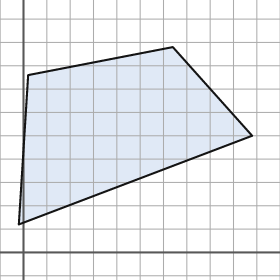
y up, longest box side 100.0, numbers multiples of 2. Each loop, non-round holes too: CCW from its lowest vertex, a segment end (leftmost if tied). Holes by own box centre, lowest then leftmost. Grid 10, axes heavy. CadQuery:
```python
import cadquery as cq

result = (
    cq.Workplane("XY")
    .moveTo(-2.0, 12.0)
    .lineTo(98.0, 50.0)
    .lineTo(64.0, 88.0)
    .lineTo(2.0, 76.0)
    .close()
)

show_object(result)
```